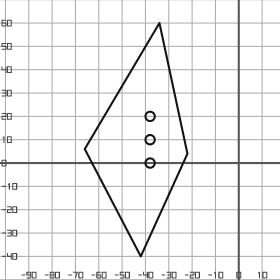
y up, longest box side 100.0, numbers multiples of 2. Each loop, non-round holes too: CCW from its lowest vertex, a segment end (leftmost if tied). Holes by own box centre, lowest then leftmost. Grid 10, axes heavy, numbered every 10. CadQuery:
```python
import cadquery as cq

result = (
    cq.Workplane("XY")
    .moveTo(-42.0, -40.0)
    .lineTo(-22.0, 4.0)
    .lineTo(-34.0, 60.0)
    .lineTo(-66.0, 6.0)
    .close()
    .moveTo(-38.0, 0.0)
    .circle(2.0)
    .moveTo(-38.0, 10.0)
    .circle(2.0)
    .moveTo(-38.0, 20.0)
    .circle(2.0)
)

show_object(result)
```